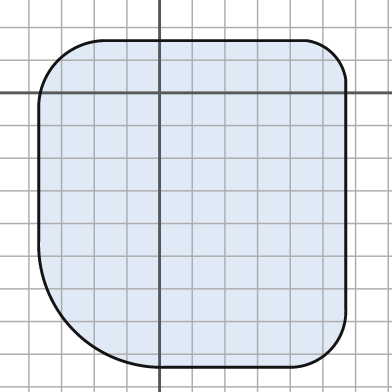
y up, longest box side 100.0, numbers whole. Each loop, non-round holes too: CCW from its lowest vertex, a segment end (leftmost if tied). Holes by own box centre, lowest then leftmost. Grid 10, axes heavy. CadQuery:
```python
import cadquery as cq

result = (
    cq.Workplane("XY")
    .moveTo(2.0, -84.0)
    .lineTo(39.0, -84.0)
    .threePointArc((52.0, -79.0), (57.0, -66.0))
    .lineTo(57.0, 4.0)
    .threePointArc((53.0, 12.0), (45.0, 16.0))
    .lineTo(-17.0, 16.0)
    .threePointArc((-31.0, 10.0), (-37.0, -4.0))
    .lineTo(-37.0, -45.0)
    .threePointArc((-26.0, -73.0), (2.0, -84.0))
    .close()
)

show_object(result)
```